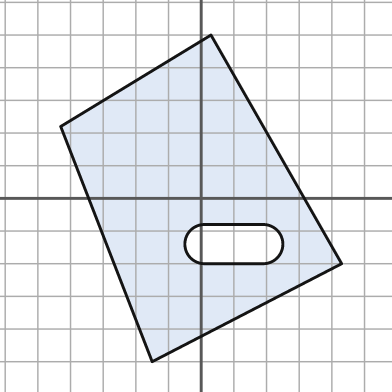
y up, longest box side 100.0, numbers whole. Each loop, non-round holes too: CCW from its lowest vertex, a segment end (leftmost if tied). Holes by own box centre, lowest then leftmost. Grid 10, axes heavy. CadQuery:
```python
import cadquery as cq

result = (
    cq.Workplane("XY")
    .moveTo(-15.0, -50.0)
    .lineTo(43.0, -20.0)
    .lineTo(3.0, 50.0)
    .lineTo(-43.0, 22.0)
    .close()
    .moveTo(1.0, -20.0)
    .lineTo(19.0, -20.0)
    .threePointArc((25.0, -14.0), (19.0, -8.0))
    .lineTo(1.0, -8.0)
    .threePointArc((-5.0, -14.0), (1.0, -20.0))
    .close()
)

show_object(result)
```